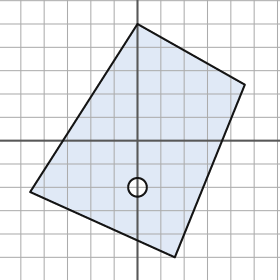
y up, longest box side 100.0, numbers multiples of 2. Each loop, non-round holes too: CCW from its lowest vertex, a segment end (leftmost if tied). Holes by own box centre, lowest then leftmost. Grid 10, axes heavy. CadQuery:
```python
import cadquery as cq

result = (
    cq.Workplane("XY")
    .moveTo(16.0, -50.0)
    .lineTo(46.0, 24.0)
    .lineTo(0.0, 50.0)
    .lineTo(-46.0, -22.0)
    .close()
    .moveTo(0.0, -20.0)
    .circle(4.0)
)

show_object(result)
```